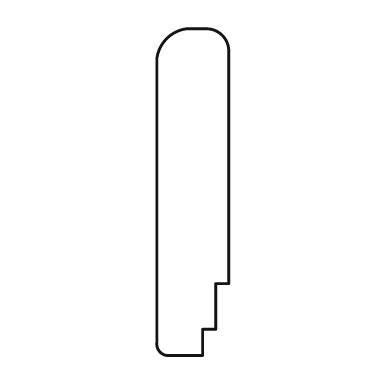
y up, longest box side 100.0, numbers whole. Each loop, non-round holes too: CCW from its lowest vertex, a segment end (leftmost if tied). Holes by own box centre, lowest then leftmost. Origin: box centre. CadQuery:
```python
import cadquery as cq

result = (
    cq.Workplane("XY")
    .moveTo(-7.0, -50.0)
    .lineTo(3.0, -50.0)
    .lineTo(3.0, -42.0)
    .lineTo(7.0, -42.0)
    .lineTo(7.0, -28.0)
    .lineTo(11.0, -28.0)
    .lineTo(11.0, 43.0)
    .threePointArc((9.0, 48.0), (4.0, 50.0))
    .lineTo(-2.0, 50.0)
    .threePointArc((-8.0, 47.0), (-11.0, 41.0))
    .lineTo(-11.0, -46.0)
    .threePointArc((-10.0, -49.0), (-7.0, -50.0))
    .close()
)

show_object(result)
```